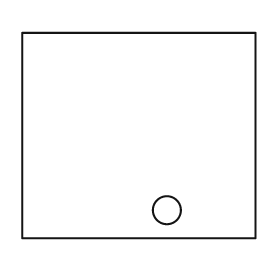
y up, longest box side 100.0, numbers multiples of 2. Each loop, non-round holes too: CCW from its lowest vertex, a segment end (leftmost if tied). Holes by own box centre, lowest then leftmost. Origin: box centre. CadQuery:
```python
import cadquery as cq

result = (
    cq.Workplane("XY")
    .moveTo(-50.0, -44.0)
    .lineTo(50.0, -44.0)
    .lineTo(50.0, 44.0)
    .lineTo(-50.0, 44.0)
    .close()
    .moveTo(12.0, -32.0)
    .circle(6.0)
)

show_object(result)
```